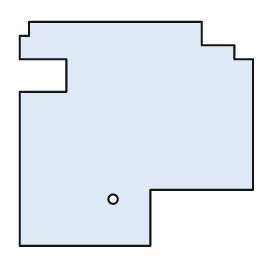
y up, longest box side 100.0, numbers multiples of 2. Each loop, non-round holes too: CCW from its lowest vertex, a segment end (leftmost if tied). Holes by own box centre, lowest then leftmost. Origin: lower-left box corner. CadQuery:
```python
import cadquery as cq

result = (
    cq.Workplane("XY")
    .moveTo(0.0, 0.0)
    .lineTo(56.0, 0.0)
    .lineTo(56.0, 24.0)
    .lineTo(100.0, 24.0)
    .lineTo(100.0, 80.0)
    .lineTo(92.0, 80.0)
    .lineTo(92.0, 86.0)
    .lineTo(78.0, 86.0)
    .lineTo(78.0, 96.0)
    .lineTo(4.0, 96.0)
    .lineTo(4.0, 90.0)
    .lineTo(0.0, 90.0)
    .lineTo(0.0, 80.0)
    .lineTo(20.0, 80.0)
    .lineTo(20.0, 66.0)
    .lineTo(0.0, 66.0)
    .close()
    .moveTo(40.0, 20.0)
    .circle(2.0)
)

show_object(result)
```